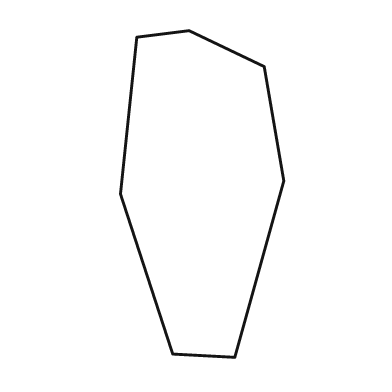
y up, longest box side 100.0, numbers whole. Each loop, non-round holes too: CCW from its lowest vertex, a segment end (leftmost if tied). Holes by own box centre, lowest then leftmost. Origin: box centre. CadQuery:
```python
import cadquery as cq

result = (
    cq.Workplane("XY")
    .moveTo(10.0, -50.0)
    .lineTo(25.0, 4.0)
    .lineTo(19.0, 39.0)
    .lineTo(-4.0, 50.0)
    .lineTo(-20.0, 48.0)
    .lineTo(-25.0, 0.0)
    .lineTo(-9.0, -49.0)
    .close()
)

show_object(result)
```